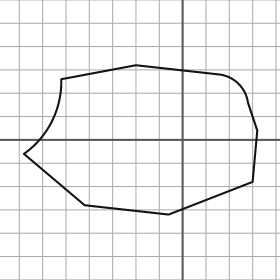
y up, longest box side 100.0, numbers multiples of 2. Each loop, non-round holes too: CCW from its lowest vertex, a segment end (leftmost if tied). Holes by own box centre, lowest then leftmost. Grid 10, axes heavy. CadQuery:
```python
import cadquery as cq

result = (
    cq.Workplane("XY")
    .moveTo(-6.0, -32.0)
    .lineTo(30.0, -18.0)
    .lineTo(32.0, 4.0)
    .lineTo(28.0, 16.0)
    .threePointArc((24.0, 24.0), (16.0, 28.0))
    .lineTo(-20.0, 32.0)
    .lineTo(-52.0, 26.0)
    .threePointArc((-56.0, 8.0), (-68.0, -6.0))
    .lineTo(-42.0, -28.0)
    .close()
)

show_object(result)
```